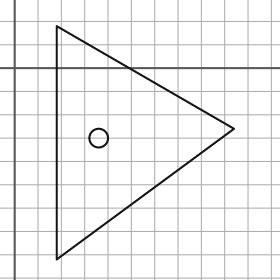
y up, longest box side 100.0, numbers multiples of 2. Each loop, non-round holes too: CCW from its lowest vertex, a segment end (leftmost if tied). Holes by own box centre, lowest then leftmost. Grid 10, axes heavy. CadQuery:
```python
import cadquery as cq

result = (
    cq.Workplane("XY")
    .moveTo(18.0, -82.0)
    .lineTo(94.0, -26.0)
    .lineTo(18.0, 18.0)
    .close()
    .moveTo(36.0, -30.0)
    .circle(4.0)
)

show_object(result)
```